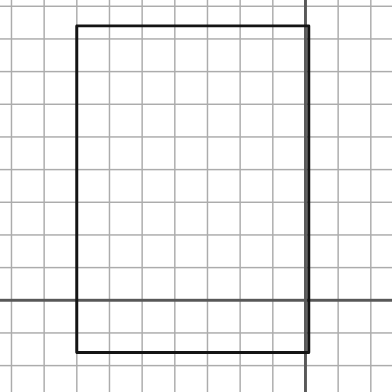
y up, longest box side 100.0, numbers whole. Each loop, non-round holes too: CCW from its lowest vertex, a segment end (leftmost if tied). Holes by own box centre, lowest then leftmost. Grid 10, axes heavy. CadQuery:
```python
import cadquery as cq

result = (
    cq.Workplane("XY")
    .moveTo(-70.0, -16.0)
    .lineTo(1.0, -16.0)
    .lineTo(1.0, 84.0)
    .lineTo(-70.0, 84.0)
    .close()
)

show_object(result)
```